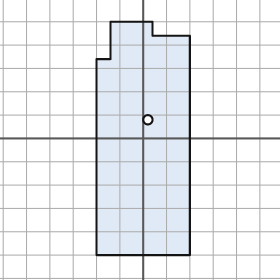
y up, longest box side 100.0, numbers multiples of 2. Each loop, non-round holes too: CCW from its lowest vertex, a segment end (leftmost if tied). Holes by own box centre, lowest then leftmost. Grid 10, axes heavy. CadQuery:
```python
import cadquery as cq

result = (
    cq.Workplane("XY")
    .moveTo(-20.0, -50.0)
    .lineTo(20.0, -50.0)
    .lineTo(20.0, 44.0)
    .lineTo(4.0, 44.0)
    .lineTo(4.0, 50.0)
    .lineTo(-14.0, 50.0)
    .lineTo(-14.0, 34.0)
    .lineTo(-20.0, 34.0)
    .close()
    .moveTo(2.0, 8.0)
    .circle(2.0)
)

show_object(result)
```